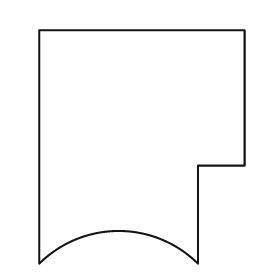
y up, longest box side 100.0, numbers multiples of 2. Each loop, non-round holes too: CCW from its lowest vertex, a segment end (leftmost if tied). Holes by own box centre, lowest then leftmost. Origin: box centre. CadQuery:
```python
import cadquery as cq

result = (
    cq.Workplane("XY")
    .moveTo(-44.0, -50.0)
    .threePointArc((-10.0, -36.0), (24.0, -50.0))
    .lineTo(24.0, -8.0)
    .lineTo(44.0, -8.0)
    .lineTo(44.0, 50.0)
    .lineTo(-44.0, 50.0)
    .close()
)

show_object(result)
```